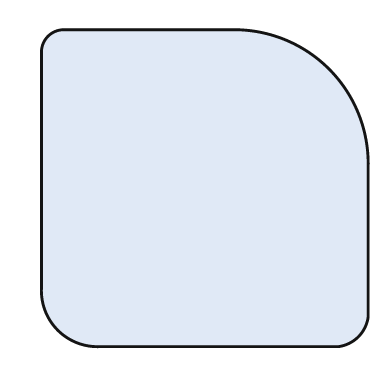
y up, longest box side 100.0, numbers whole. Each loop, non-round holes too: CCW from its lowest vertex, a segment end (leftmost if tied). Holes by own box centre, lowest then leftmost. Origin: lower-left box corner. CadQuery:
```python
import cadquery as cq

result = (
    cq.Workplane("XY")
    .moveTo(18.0, 0.0)
    .lineTo(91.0, 0.0)
    .threePointArc((97.0, 3.0), (100.0, 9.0))
    .lineTo(100.0, 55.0)
    .threePointArc((88.0, 85.0), (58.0, 97.0))
    .lineTo(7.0, 97.0)
    .threePointArc((2.0, 95.0), (0.0, 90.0))
    .lineTo(0.0, 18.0)
    .threePointArc((5.0, 5.0), (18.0, 0.0))
    .close()
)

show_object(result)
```